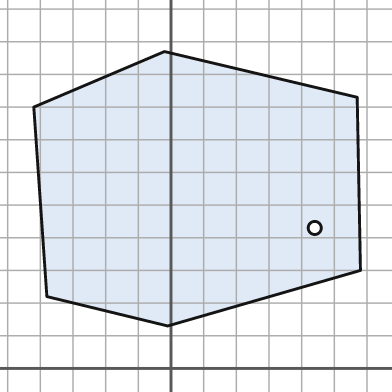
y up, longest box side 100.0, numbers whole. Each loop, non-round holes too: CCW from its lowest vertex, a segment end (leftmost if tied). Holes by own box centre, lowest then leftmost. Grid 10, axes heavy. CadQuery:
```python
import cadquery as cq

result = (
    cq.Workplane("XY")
    .moveTo(-1.0, 13.0)
    .lineTo(58.0, 30.0)
    .lineTo(57.0, 83.0)
    .lineTo(-2.0, 97.0)
    .lineTo(-42.0, 80.0)
    .lineTo(-38.0, 22.0)
    .close()
    .moveTo(44.0, 43.0)
    .circle(2.0)
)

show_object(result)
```